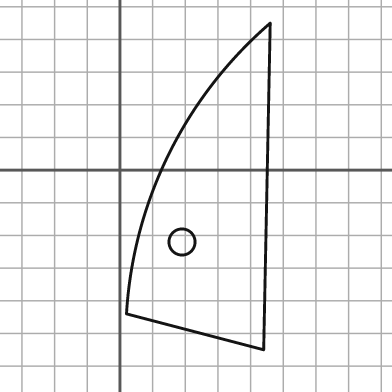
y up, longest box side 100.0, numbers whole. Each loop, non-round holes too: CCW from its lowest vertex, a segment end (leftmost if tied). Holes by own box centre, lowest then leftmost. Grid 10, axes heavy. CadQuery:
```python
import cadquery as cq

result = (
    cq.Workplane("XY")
    .moveTo(44.0, -55.0)
    .lineTo(46.0, 45.0)
    .threePointArc((15.0, 5.0), (2.0, -44.0))
    .close()
    .moveTo(19.0, -22.0)
    .circle(4.0)
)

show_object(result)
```